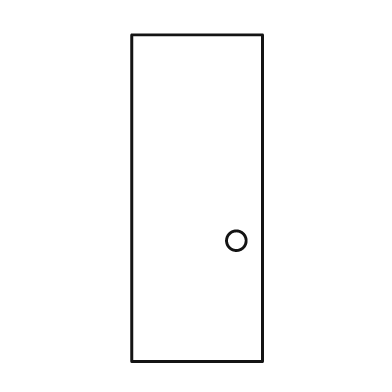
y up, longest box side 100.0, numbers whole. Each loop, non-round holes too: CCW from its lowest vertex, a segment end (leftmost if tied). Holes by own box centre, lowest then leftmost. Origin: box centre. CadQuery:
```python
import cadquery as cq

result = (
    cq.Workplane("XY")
    .moveTo(-20.0, -50.0)
    .lineTo(20.0, -50.0)
    .lineTo(20.0, 50.0)
    .lineTo(-20.0, 50.0)
    .close()
    .moveTo(12.0, -13.0)
    .circle(3.0)
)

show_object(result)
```